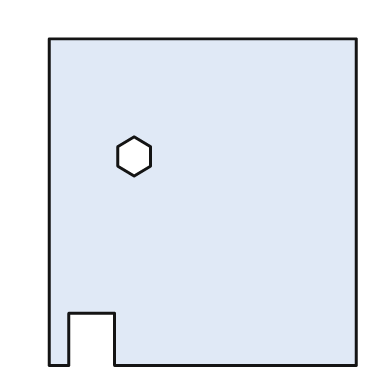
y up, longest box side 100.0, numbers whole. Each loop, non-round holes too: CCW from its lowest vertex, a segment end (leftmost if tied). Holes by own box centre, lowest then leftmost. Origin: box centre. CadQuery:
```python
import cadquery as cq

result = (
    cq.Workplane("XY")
    .moveTo(-47.0, -50.0)
    .lineTo(-41.0, -50.0)
    .lineTo(-41.0, -34.0)
    .lineTo(-27.0, -34.0)
    .lineTo(-27.0, -50.0)
    .lineTo(47.0, -50.0)
    .lineTo(47.0, 50.0)
    .lineTo(-47.0, 50.0)
    .close()
    .moveTo(-21.0, 8.0)
    .lineTo(-16.0, 11.0)
    .lineTo(-16.0, 17.0)
    .lineTo(-21.0, 20.0)
    .lineTo(-26.0, 17.0)
    .lineTo(-26.0, 11.0)
    .close()
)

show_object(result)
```